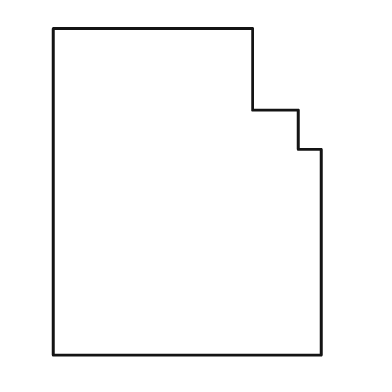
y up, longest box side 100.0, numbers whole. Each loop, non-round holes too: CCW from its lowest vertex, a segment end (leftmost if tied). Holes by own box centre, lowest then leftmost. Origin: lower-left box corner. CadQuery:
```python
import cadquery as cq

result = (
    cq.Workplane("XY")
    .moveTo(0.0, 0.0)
    .lineTo(82.0, 0.0)
    .lineTo(82.0, 63.0)
    .lineTo(75.0, 63.0)
    .lineTo(75.0, 75.0)
    .lineTo(61.0, 75.0)
    .lineTo(61.0, 100.0)
    .lineTo(0.0, 100.0)
    .close()
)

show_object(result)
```